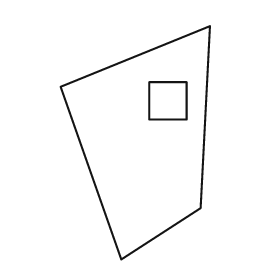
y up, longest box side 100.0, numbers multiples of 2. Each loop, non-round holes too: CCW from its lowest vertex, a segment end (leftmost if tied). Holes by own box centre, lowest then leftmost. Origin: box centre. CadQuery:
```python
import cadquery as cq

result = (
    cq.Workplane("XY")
    .moveTo(-6.0, -50.0)
    .lineTo(28.0, -28.0)
    .lineTo(32.0, 50.0)
    .lineTo(-32.0, 24.0)
    .close()
    .moveTo(6.0, 10.0)
    .lineTo(22.0, 10.0)
    .lineTo(22.0, 26.0)
    .lineTo(6.0, 26.0)
    .close()
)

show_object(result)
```